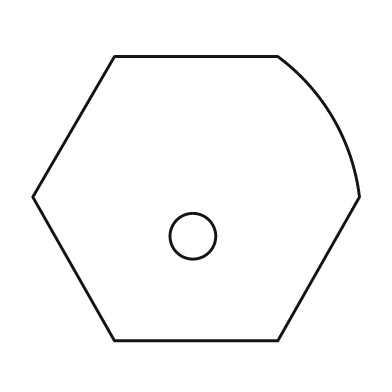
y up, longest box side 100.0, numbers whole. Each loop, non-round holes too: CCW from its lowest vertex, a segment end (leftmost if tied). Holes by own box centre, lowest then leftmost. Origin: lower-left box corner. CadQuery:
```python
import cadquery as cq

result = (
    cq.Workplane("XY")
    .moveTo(25.0, 0.0)
    .lineTo(75.0, 0.0)
    .lineTo(100.0, 44.0)
    .threePointArc((92.0, 68.0), (75.0, 87.0))
    .lineTo(25.0, 87.0)
    .lineTo(0.0, 44.0)
    .close()
    .moveTo(49.0, 32.0)
    .circle(7.0)
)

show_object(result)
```